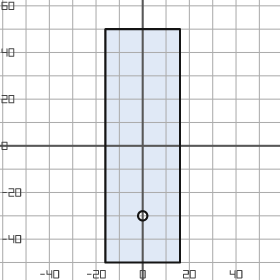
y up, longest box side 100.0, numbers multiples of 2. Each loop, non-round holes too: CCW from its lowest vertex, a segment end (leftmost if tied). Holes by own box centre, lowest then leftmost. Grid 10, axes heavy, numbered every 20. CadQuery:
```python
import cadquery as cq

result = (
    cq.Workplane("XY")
    .moveTo(-16.0, -50.0)
    .lineTo(16.0, -50.0)
    .lineTo(16.0, 50.0)
    .lineTo(-16.0, 50.0)
    .close()
    .moveTo(0.0, -30.0)
    .circle(2.0)
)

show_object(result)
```